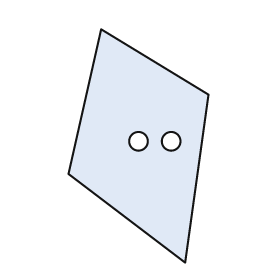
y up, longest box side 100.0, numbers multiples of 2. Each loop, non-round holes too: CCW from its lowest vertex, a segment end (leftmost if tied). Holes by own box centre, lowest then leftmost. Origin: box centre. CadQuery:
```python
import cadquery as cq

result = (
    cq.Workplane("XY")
    .moveTo(20.0, -50.0)
    .lineTo(30.0, 22.0)
    .lineTo(-16.0, 50.0)
    .lineTo(-30.0, -12.0)
    .close()
    .moveTo(0.0, 2.0)
    .circle(4.0)
    .moveTo(14.0, 2.0)
    .circle(4.0)
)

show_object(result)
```